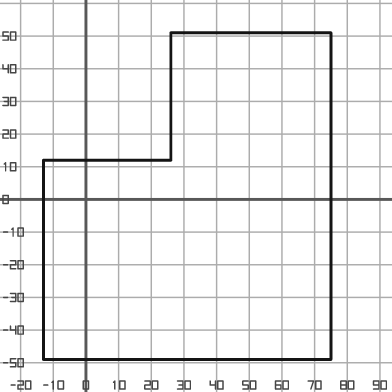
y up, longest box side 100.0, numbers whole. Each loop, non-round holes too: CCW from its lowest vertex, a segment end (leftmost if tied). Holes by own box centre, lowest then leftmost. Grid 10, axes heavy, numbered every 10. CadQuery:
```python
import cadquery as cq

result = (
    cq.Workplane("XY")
    .moveTo(-13.0, -49.0)
    .lineTo(75.0, -49.0)
    .lineTo(75.0, 51.0)
    .lineTo(26.0, 51.0)
    .lineTo(26.0, 12.0)
    .lineTo(-13.0, 12.0)
    .close()
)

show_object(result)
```